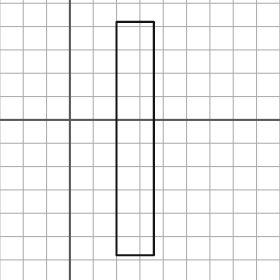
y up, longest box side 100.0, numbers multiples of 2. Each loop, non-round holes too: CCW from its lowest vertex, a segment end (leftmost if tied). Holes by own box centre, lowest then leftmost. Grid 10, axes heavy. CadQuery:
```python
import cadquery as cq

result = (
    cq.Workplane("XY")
    .moveTo(20.0, -58.0)
    .lineTo(36.0, -58.0)
    .lineTo(36.0, 42.0)
    .lineTo(20.0, 42.0)
    .close()
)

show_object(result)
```